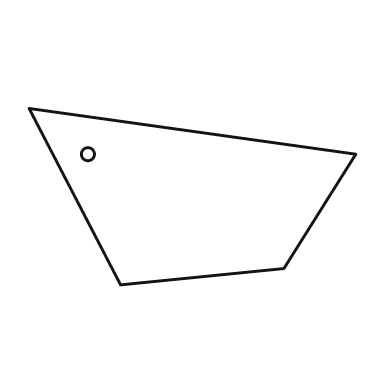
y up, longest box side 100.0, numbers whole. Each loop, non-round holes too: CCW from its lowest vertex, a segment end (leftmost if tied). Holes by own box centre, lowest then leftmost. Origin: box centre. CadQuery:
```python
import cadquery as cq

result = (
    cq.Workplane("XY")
    .moveTo(-22.0, -27.0)
    .lineTo(28.0, -22.0)
    .lineTo(50.0, 13.0)
    .lineTo(-50.0, 27.0)
    .close()
    .moveTo(-32.0, 13.0)
    .circle(2.0)
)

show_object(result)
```